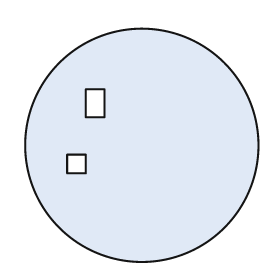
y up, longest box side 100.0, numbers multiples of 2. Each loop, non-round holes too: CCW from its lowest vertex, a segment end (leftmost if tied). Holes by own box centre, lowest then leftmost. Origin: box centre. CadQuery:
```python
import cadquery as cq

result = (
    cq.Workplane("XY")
    .moveTo(0.0, 0.0)
    .circle(50.0)
    .moveTo(-32.0, -12.0)
    .lineTo(-24.0, -12.0)
    .lineTo(-24.0, -4.0)
    .lineTo(-32.0, -4.0)
    .close()
    .moveTo(-24.0, 12.0)
    .lineTo(-16.0, 12.0)
    .lineTo(-16.0, 24.0)
    .lineTo(-24.0, 24.0)
    .close()
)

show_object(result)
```